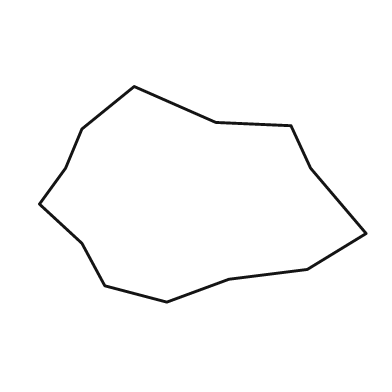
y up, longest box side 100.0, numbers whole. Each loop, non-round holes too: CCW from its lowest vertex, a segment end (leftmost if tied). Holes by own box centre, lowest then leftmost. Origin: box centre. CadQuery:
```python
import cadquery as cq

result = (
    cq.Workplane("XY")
    .moveTo(-11.0, -33.0)
    .lineTo(8.0, -26.0)
    .lineTo(32.0, -23.0)
    .lineTo(50.0, -12.0)
    .lineTo(33.0, 8.0)
    .lineTo(27.0, 21.0)
    .lineTo(4.0, 22.0)
    .lineTo(-21.0, 33.0)
    .lineTo(-37.0, 20.0)
    .lineTo(-42.0, 8.0)
    .lineTo(-50.0, -3.0)
    .lineTo(-37.0, -15.0)
    .lineTo(-30.0, -28.0)
    .close()
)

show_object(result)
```